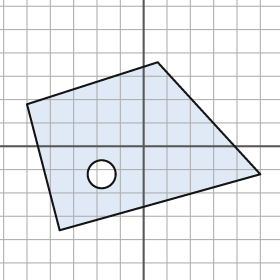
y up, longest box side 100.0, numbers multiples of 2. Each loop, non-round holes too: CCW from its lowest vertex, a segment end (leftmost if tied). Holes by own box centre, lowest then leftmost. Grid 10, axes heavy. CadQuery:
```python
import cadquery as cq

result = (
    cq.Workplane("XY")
    .moveTo(-36.0, -36.0)
    .lineTo(50.0, -12.0)
    .lineTo(6.0, 36.0)
    .lineTo(-50.0, 18.0)
    .close()
    .moveTo(-18.0, -12.0)
    .circle(6.0)
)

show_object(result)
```